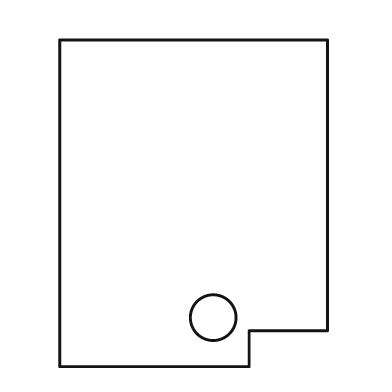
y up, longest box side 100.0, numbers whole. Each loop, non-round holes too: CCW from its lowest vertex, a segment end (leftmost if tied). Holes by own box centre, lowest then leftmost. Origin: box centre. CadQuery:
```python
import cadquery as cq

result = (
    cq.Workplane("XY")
    .moveTo(-41.0, -50.0)
    .lineTo(17.0, -50.0)
    .lineTo(17.0, -39.0)
    .lineTo(41.0, -39.0)
    .lineTo(41.0, 50.0)
    .lineTo(-41.0, 50.0)
    .close()
    .moveTo(6.0, -35.0)
    .circle(7.0)
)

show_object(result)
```